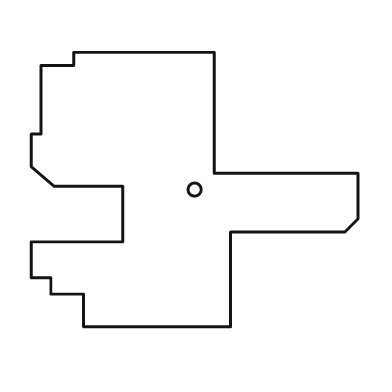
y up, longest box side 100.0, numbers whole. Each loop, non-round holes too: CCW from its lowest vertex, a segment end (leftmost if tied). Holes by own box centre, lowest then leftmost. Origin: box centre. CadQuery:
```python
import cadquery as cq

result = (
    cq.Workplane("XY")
    .moveTo(-34.0, -42.0)
    .lineTo(11.0, -42.0)
    .lineTo(11.0, -13.0)
    .lineTo(46.0, -13.0)
    .lineTo(50.0, -9.0)
    .lineTo(50.0, 5.0)
    .lineTo(6.0, 5.0)
    .lineTo(6.0, 42.0)
    .lineTo(-37.0, 42.0)
    .lineTo(-37.0, 38.0)
    .lineTo(-47.0, 38.0)
    .lineTo(-47.0, 17.0)
    .lineTo(-50.0, 17.0)
    .lineTo(-50.0, 7.0)
    .lineTo(-43.0, 1.0)
    .lineTo(-22.0, 1.0)
    .lineTo(-22.0, -16.0)
    .lineTo(-50.0, -16.0)
    .lineTo(-50.0, -27.0)
    .lineTo(-44.0, -27.0)
    .lineTo(-44.0, -32.0)
    .lineTo(-34.0, -32.0)
    .close()
    .moveTo(0.0, 0.0)
    .circle(2.0)
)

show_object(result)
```